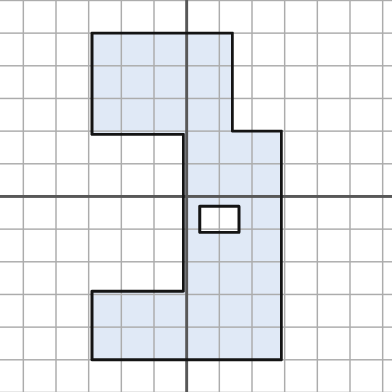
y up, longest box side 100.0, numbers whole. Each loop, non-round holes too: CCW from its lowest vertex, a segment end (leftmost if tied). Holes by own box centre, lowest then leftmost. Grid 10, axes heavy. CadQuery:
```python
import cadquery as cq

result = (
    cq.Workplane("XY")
    .moveTo(-29.0, -50.0)
    .lineTo(29.0, -50.0)
    .lineTo(29.0, 20.0)
    .lineTo(14.0, 20.0)
    .lineTo(14.0, 50.0)
    .lineTo(-29.0, 50.0)
    .lineTo(-29.0, 19.0)
    .lineTo(-1.0, 19.0)
    .lineTo(-1.0, -29.0)
    .lineTo(-29.0, -29.0)
    .close()
    .moveTo(4.0, -11.0)
    .lineTo(16.0, -11.0)
    .lineTo(16.0, -3.0)
    .lineTo(4.0, -3.0)
    .close()
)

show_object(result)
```